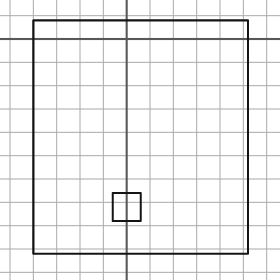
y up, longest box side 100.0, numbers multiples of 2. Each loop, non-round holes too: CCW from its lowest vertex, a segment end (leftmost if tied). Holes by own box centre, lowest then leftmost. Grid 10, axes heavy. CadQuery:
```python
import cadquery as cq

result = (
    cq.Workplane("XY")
    .moveTo(-40.0, -92.0)
    .lineTo(52.0, -92.0)
    .lineTo(52.0, 8.0)
    .lineTo(-40.0, 8.0)
    .close()
    .moveTo(-6.0, -78.0)
    .lineTo(6.0, -78.0)
    .lineTo(6.0, -66.0)
    .lineTo(-6.0, -66.0)
    .close()
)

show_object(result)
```